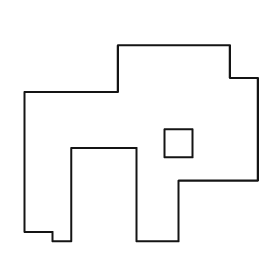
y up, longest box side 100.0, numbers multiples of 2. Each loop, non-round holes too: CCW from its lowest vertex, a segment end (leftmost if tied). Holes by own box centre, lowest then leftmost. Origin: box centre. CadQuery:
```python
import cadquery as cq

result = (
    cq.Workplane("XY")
    .moveTo(-38.0, -42.0)
    .lineTo(-30.0, -42.0)
    .lineTo(-30.0, -2.0)
    .lineTo(-2.0, -2.0)
    .lineTo(-2.0, -42.0)
    .lineTo(16.0, -42.0)
    .lineTo(16.0, -16.0)
    .lineTo(50.0, -16.0)
    .lineTo(50.0, 28.0)
    .lineTo(38.0, 28.0)
    .lineTo(38.0, 42.0)
    .lineTo(-10.0, 42.0)
    .lineTo(-10.0, 22.0)
    .lineTo(-50.0, 22.0)
    .lineTo(-50.0, -38.0)
    .lineTo(-38.0, -38.0)
    .close()
    .moveTo(10.0, -6.0)
    .lineTo(22.0, -6.0)
    .lineTo(22.0, 6.0)
    .lineTo(10.0, 6.0)
    .close()
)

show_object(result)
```